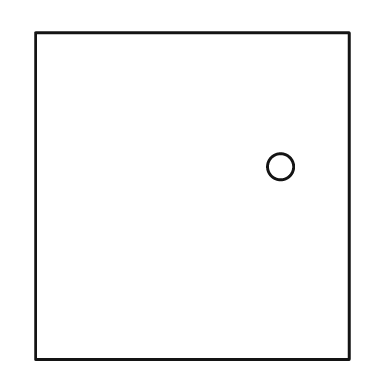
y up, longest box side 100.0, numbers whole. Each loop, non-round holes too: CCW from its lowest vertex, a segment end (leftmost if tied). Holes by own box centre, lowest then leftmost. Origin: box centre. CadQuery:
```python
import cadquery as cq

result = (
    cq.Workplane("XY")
    .moveTo(-48.0, -50.0)
    .lineTo(48.0, -50.0)
    .lineTo(48.0, 50.0)
    .lineTo(-48.0, 50.0)
    .close()
    .moveTo(27.0, 9.0)
    .circle(4.0)
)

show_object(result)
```